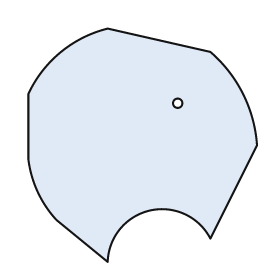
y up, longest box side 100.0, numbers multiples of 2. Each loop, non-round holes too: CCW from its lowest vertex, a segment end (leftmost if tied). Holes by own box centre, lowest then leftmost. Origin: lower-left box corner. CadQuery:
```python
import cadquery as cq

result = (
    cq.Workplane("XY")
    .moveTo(34.0, 0.0)
    .threePointArc((52.0, 22.0), (78.0, 10.0))
    .lineTo(98.0, 50.0)
    .threePointArc((92.0, 72.0), (78.0, 90.0))
    .lineTo(34.0, 100.0)
    .threePointArc((14.0, 90.0), (0.0, 72.0))
    .lineTo(0.0, 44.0)
    .threePointArc((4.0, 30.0), (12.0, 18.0))
    .close()
    .moveTo(64.0, 68.0)
    .circle(2.0)
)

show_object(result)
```